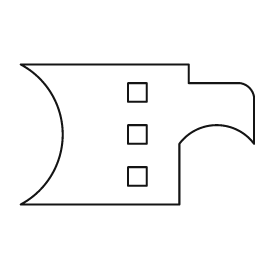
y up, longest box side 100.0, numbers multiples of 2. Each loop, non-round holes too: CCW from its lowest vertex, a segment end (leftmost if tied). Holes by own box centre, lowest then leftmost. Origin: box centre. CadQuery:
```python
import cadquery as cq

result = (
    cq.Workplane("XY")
    .moveTo(-50.0, -30.0)
    .lineTo(18.0, -30.0)
    .lineTo(18.0, -4.0)
    .threePointArc((34.0, 4.0), (50.0, -4.0))
    .lineTo(50.0, 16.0)
    .threePointArc((48.0, 20.0), (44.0, 22.0))
    .lineTo(22.0, 22.0)
    .lineTo(22.0, 30.0)
    .lineTo(-50.0, 30.0)
    .threePointArc((-32.0, 0.0), (-50.0, -30.0))
    .close()
    .moveTo(-4.0, -22.0)
    .lineTo(4.0, -22.0)
    .lineTo(4.0, -14.0)
    .lineTo(-4.0, -14.0)
    .close()
    .moveTo(-4.0, -4.0)
    .lineTo(4.0, -4.0)
    .lineTo(4.0, 4.0)
    .lineTo(-4.0, 4.0)
    .close()
    .moveTo(-4.0, 14.0)
    .lineTo(4.0, 14.0)
    .lineTo(4.0, 22.0)
    .lineTo(-4.0, 22.0)
    .close()
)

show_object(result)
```